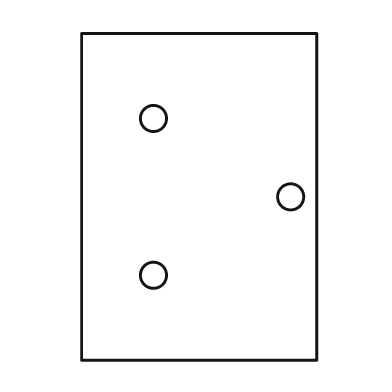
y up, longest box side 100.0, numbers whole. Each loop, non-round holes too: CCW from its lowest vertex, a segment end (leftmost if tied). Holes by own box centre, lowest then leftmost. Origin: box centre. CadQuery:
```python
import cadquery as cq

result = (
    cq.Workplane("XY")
    .moveTo(-36.0, -50.0)
    .lineTo(36.0, -50.0)
    .lineTo(36.0, 50.0)
    .lineTo(-36.0, 50.0)
    .close()
    .moveTo(-14.0, -24.0)
    .circle(4.0)
    .moveTo(28.0, 0.0)
    .circle(4.0)
    .moveTo(-14.0, 24.0)
    .circle(4.0)
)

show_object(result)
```